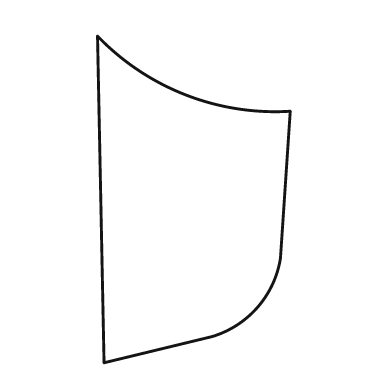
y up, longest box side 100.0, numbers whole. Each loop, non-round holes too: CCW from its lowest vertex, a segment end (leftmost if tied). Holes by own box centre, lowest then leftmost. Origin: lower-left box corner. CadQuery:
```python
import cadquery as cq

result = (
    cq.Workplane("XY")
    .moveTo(2.0, 0.0)
    .lineTo(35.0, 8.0)
    .threePointArc((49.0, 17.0), (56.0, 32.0))
    .lineTo(59.0, 77.0)
    .threePointArc((27.0, 82.0), (0.0, 100.0))
    .close()
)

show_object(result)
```